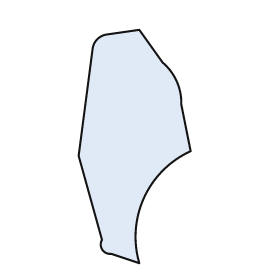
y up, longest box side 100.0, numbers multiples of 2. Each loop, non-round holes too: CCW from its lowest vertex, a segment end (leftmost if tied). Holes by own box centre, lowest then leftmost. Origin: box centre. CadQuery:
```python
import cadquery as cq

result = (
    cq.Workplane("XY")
    .moveTo(2.0, -50.0)
    .threePointArc((4.0, -22.0), (24.0, -2.0))
    .lineTo(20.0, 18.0)
    .threePointArc((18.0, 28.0), (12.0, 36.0))
    .lineTo(2.0, 50.0)
    .lineTo(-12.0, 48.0)
    .threePointArc((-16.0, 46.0), (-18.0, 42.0))
    .lineTo(-24.0, -4.0)
    .lineTo(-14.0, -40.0)
    .threePointArc((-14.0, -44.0), (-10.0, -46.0))
    .close()
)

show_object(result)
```